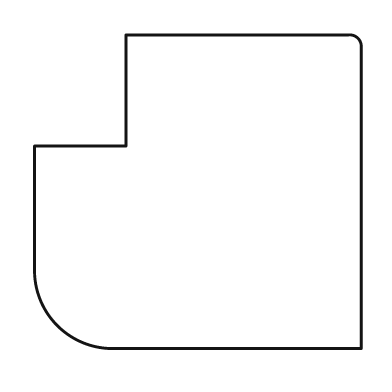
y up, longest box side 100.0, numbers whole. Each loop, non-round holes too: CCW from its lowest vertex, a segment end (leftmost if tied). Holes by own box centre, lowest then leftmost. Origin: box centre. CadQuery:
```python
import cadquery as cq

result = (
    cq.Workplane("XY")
    .moveTo(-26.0, -48.0)
    .lineTo(50.0, -48.0)
    .lineTo(50.0, 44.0)
    .threePointArc((49.0, 47.0), (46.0, 48.0))
    .lineTo(-22.0, 48.0)
    .lineTo(-22.0, 14.0)
    .lineTo(-50.0, 14.0)
    .lineTo(-50.0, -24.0)
    .threePointArc((-43.0, -41.0), (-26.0, -48.0))
    .close()
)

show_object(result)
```